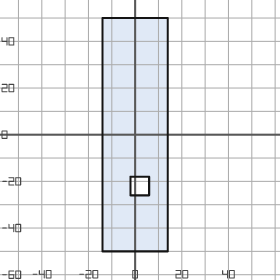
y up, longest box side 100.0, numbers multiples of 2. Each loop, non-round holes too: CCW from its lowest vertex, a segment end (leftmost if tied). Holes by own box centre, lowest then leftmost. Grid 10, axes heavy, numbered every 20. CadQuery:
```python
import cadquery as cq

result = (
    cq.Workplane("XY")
    .moveTo(-14.0, -50.0)
    .lineTo(14.0, -50.0)
    .lineTo(14.0, 50.0)
    .lineTo(-14.0, 50.0)
    .close()
    .moveTo(-2.0, -26.0)
    .lineTo(6.0, -26.0)
    .lineTo(6.0, -18.0)
    .lineTo(-2.0, -18.0)
    .close()
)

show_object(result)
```